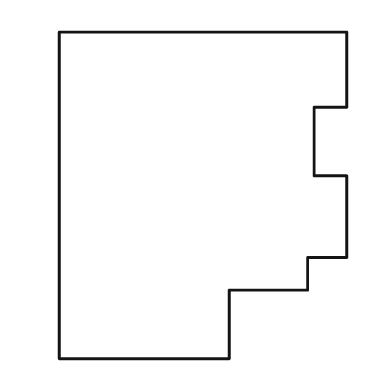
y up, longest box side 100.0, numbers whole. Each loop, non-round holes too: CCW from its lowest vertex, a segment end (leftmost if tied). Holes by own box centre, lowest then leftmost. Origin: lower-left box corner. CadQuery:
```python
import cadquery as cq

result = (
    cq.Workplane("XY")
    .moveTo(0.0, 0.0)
    .lineTo(52.0, 0.0)
    .lineTo(52.0, 21.0)
    .lineTo(76.0, 21.0)
    .lineTo(76.0, 31.0)
    .lineTo(88.0, 31.0)
    .lineTo(88.0, 56.0)
    .lineTo(78.0, 56.0)
    .lineTo(78.0, 77.0)
    .lineTo(88.0, 77.0)
    .lineTo(88.0, 100.0)
    .lineTo(0.0, 100.0)
    .close()
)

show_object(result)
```